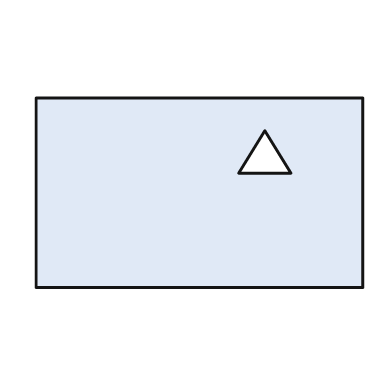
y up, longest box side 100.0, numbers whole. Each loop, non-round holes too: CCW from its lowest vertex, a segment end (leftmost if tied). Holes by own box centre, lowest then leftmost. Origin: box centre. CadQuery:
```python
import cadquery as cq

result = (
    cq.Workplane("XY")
    .moveTo(-50.0, -29.0)
    .lineTo(50.0, -29.0)
    .lineTo(50.0, 29.0)
    .lineTo(-50.0, 29.0)
    .close()
    .moveTo(12.0, 6.0)
    .lineTo(28.0, 6.0)
    .lineTo(20.0, 19.0)
    .close()
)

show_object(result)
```